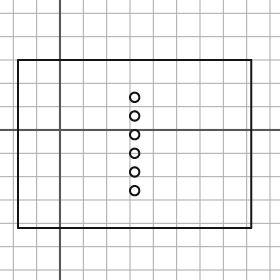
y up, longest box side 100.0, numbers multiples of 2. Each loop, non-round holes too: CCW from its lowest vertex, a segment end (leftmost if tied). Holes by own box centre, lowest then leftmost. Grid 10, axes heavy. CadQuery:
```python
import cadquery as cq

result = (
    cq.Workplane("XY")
    .moveTo(-18.0, -42.0)
    .lineTo(82.0, -42.0)
    .lineTo(82.0, 30.0)
    .lineTo(-18.0, 30.0)
    .close()
    .moveTo(32.0, -26.0)
    .circle(2.0)
    .moveTo(32.0, -18.0)
    .circle(2.0)
    .moveTo(32.0, -10.0)
    .circle(2.0)
    .moveTo(32.0, -2.0)
    .circle(2.0)
    .moveTo(32.0, 6.0)
    .circle(2.0)
    .moveTo(32.0, 14.0)
    .circle(2.0)
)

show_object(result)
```